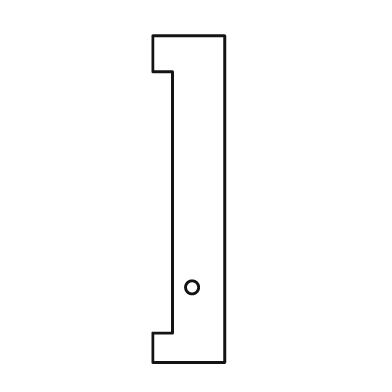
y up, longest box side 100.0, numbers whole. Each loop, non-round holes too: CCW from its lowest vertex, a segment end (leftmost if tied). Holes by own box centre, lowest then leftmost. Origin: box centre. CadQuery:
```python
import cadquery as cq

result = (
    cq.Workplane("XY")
    .moveTo(-11.0, -50.0)
    .lineTo(11.0, -50.0)
    .lineTo(11.0, 50.0)
    .lineTo(-11.0, 50.0)
    .lineTo(-11.0, 39.0)
    .lineTo(-5.0, 39.0)
    .lineTo(-5.0, -41.0)
    .lineTo(-11.0, -41.0)
    .close()
    .moveTo(1.0, -27.0)
    .circle(2.0)
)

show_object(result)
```